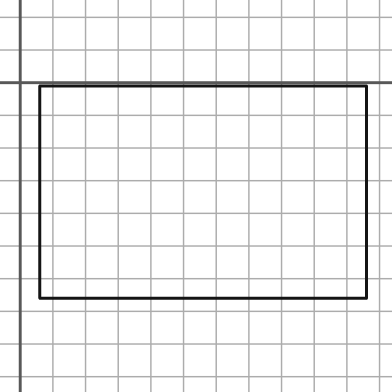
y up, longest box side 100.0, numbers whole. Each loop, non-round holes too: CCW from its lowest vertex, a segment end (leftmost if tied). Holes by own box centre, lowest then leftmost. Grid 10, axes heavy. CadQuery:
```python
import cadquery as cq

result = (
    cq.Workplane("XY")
    .moveTo(6.0, -66.0)
    .lineTo(106.0, -66.0)
    .lineTo(106.0, -1.0)
    .lineTo(6.0, -1.0)
    .close()
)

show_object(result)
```